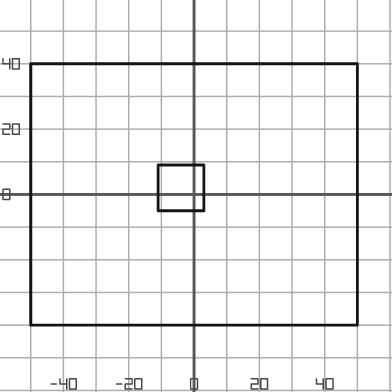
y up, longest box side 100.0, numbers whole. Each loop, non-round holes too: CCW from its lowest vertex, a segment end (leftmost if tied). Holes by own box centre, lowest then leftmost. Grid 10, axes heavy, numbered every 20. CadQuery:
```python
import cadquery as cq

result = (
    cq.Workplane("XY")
    .moveTo(-50.0, -40.0)
    .lineTo(50.0, -40.0)
    .lineTo(50.0, 40.0)
    .lineTo(-50.0, 40.0)
    .close()
    .moveTo(-11.0, -5.0)
    .lineTo(3.0, -5.0)
    .lineTo(3.0, 9.0)
    .lineTo(-11.0, 9.0)
    .close()
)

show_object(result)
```